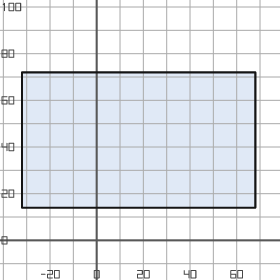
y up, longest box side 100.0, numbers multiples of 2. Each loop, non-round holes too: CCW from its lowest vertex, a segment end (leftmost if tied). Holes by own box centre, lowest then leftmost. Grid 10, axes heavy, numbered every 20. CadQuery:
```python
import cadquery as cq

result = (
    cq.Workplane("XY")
    .moveTo(-32.0, 14.0)
    .lineTo(68.0, 14.0)
    .lineTo(68.0, 72.0)
    .lineTo(-32.0, 72.0)
    .close()
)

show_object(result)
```